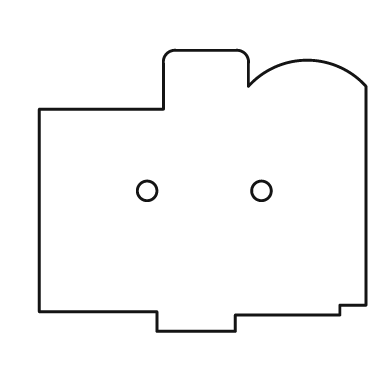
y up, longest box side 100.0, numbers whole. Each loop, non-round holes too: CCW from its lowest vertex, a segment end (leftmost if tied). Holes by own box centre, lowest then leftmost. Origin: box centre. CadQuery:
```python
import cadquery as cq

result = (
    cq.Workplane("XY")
    .moveTo(-14.0, -43.0)
    .lineTo(10.0, -43.0)
    .lineTo(10.0, -38.0)
    .lineTo(42.0, -38.0)
    .lineTo(42.0, -35.0)
    .lineTo(50.0, -35.0)
    .lineTo(50.0, 32.0)
    .threePointArc((32.0, 40.0), (14.0, 32.0))
    .lineTo(14.0, 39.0)
    .threePointArc((13.0, 42.0), (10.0, 43.0))
    .lineTo(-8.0, 43.0)
    .threePointArc((-11.0, 42.0), (-12.0, 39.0))
    .lineTo(-12.0, 25.0)
    .lineTo(-50.0, 25.0)
    .lineTo(-50.0, -37.0)
    .lineTo(-14.0, -37.0)
    .close()
    .moveTo(-17.0, 0.0)
    .circle(3.0)
    .moveTo(18.0, 0.0)
    .circle(3.0)
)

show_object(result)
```